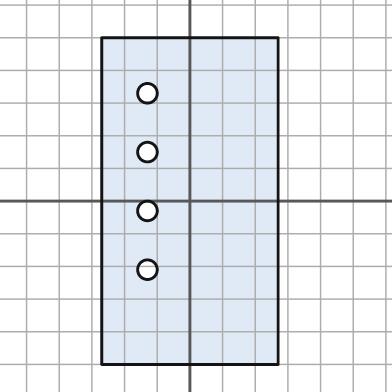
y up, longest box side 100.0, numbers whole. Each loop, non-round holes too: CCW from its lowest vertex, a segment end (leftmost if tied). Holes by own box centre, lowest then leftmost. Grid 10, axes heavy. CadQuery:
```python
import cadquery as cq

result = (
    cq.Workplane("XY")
    .moveTo(-27.0, -50.0)
    .lineTo(27.0, -50.0)
    .lineTo(27.0, 50.0)
    .lineTo(-27.0, 50.0)
    .close()
    .moveTo(-13.0, -21.0)
    .circle(3.0)
    .moveTo(-13.0, -3.0)
    .circle(3.0)
    .moveTo(-13.0, 15.0)
    .circle(3.0)
    .moveTo(-13.0, 33.0)
    .circle(3.0)
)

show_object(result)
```